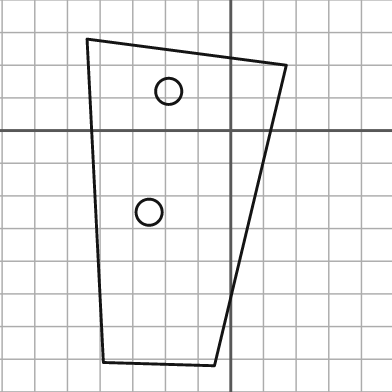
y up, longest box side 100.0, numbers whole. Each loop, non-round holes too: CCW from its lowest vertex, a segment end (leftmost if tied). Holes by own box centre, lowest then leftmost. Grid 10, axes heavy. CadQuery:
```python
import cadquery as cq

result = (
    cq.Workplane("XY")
    .moveTo(-5.0, -72.0)
    .lineTo(17.0, 20.0)
    .lineTo(-44.0, 28.0)
    .lineTo(-39.0, -71.0)
    .close()
    .moveTo(-25.0, -25.0)
    .circle(4.0)
    .moveTo(-19.0, 12.0)
    .circle(4.0)
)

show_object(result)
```